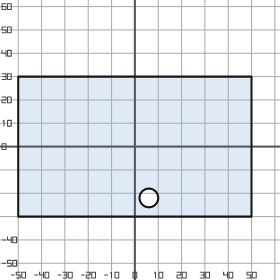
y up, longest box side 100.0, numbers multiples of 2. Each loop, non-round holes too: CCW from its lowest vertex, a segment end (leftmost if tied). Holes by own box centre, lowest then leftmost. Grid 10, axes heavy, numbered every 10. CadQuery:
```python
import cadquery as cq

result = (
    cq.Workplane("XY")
    .moveTo(-50.0, -30.0)
    .lineTo(50.0, -30.0)
    .lineTo(50.0, 30.0)
    .lineTo(-50.0, 30.0)
    .close()
    .moveTo(6.0, -22.0)
    .circle(4.0)
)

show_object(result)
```